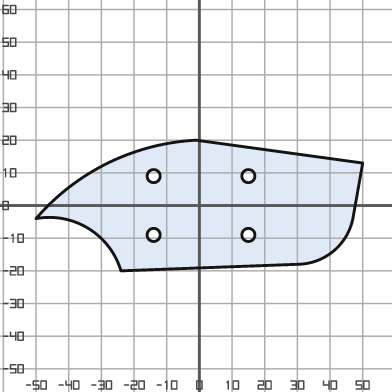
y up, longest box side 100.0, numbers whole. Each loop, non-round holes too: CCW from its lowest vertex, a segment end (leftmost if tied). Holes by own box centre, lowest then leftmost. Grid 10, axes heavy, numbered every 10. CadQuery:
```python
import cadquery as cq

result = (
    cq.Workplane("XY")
    .moveTo(-24.0, -20.0)
    .lineTo(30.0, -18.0)
    .threePointArc((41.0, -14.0), (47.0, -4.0))
    .lineTo(50.0, 13.0)
    .lineTo(-1.0, 20.0)
    .threePointArc((-28.0, 13.0), (-50.0, -4.0))
    .threePointArc((-34.0, -7.0), (-24.0, -20.0))
    .close()
    .moveTo(-14.0, -9.0)
    .circle(2.0)
    .moveTo(15.0, -9.0)
    .circle(2.0)
    .moveTo(-14.0, 9.0)
    .circle(2.0)
    .moveTo(15.0, 9.0)
    .circle(2.0)
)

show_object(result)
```